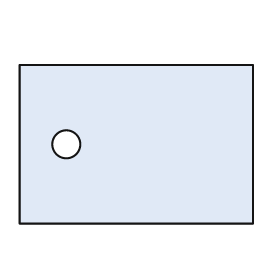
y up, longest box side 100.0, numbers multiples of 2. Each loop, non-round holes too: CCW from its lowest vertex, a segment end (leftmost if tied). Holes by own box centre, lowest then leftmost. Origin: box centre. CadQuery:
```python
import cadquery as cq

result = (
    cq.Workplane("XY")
    .moveTo(-50.0, -34.0)
    .lineTo(50.0, -34.0)
    .lineTo(50.0, 34.0)
    .lineTo(-50.0, 34.0)
    .close()
    .moveTo(-30.0, 0.0)
    .circle(6.0)
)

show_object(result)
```